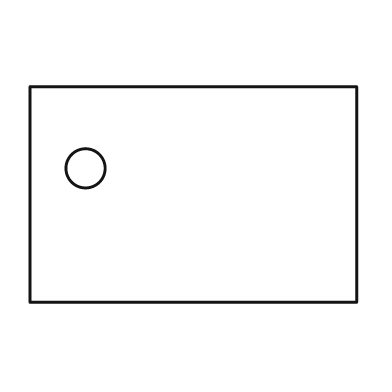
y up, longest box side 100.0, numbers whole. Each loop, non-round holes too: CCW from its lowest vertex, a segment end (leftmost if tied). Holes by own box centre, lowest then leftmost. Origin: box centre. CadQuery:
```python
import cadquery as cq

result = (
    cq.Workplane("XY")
    .moveTo(-50.0, -33.0)
    .lineTo(50.0, -33.0)
    .lineTo(50.0, 33.0)
    .lineTo(-50.0, 33.0)
    .close()
    .moveTo(-33.0, 8.0)
    .circle(6.0)
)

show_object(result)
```